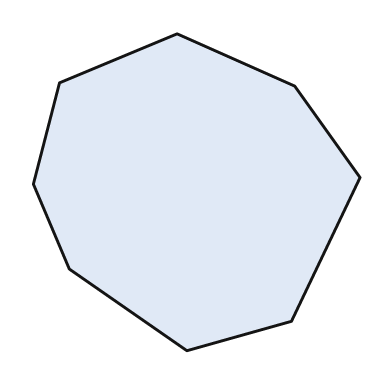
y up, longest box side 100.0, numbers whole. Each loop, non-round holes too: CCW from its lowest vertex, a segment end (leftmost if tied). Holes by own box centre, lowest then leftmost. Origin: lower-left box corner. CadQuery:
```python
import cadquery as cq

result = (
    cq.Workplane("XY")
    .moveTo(47.0, 0.0)
    .lineTo(79.0, 9.0)
    .lineTo(100.0, 53.0)
    .lineTo(80.0, 81.0)
    .lineTo(44.0, 97.0)
    .lineTo(8.0, 82.0)
    .lineTo(0.0, 51.0)
    .lineTo(11.0, 25.0)
    .close()
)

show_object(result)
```